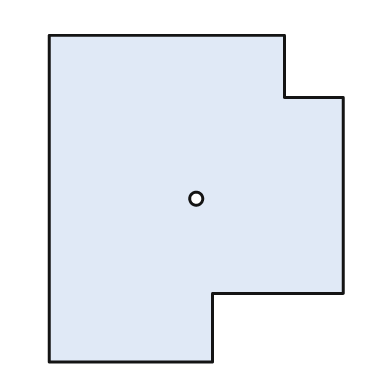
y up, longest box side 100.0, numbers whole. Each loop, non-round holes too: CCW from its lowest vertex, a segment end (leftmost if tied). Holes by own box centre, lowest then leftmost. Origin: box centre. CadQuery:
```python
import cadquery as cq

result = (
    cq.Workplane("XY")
    .moveTo(-45.0, -50.0)
    .lineTo(5.0, -50.0)
    .lineTo(5.0, -29.0)
    .lineTo(45.0, -29.0)
    .lineTo(45.0, 31.0)
    .lineTo(27.0, 31.0)
    .lineTo(27.0, 50.0)
    .lineTo(-45.0, 50.0)
    .close()
    .moveTo(0.0, 0.0)
    .circle(2.0)
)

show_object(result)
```